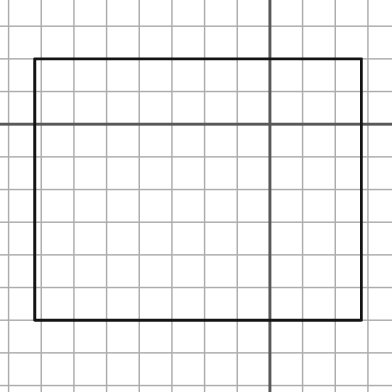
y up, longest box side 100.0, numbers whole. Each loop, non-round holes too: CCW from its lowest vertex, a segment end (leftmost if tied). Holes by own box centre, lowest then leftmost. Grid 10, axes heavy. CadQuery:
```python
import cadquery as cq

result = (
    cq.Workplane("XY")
    .moveTo(-72.0, -60.0)
    .lineTo(28.0, -60.0)
    .lineTo(28.0, 20.0)
    .lineTo(-72.0, 20.0)
    .close()
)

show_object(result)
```